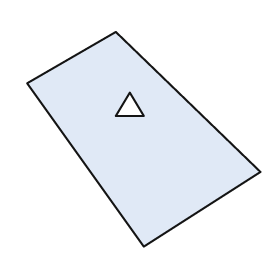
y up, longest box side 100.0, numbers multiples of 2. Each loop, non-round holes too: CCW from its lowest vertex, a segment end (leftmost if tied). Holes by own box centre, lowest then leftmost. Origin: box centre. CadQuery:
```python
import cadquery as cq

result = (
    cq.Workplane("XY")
    .moveTo(0.0, -46.0)
    .lineTo(50.0, -14.0)
    .lineTo(-12.0, 46.0)
    .lineTo(-50.0, 24.0)
    .close()
    .moveTo(-12.0, 10.0)
    .lineTo(0.0, 10.0)
    .lineTo(-6.0, 20.0)
    .close()
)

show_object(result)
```